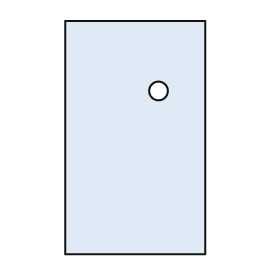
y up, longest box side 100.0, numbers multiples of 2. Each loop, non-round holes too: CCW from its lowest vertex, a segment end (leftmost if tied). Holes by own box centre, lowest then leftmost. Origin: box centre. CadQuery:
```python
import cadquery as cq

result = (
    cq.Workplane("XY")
    .moveTo(-30.0, -50.0)
    .lineTo(30.0, -50.0)
    .lineTo(30.0, 50.0)
    .lineTo(-30.0, 50.0)
    .close()
    .moveTo(10.0, 20.0)
    .circle(4.0)
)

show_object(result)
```